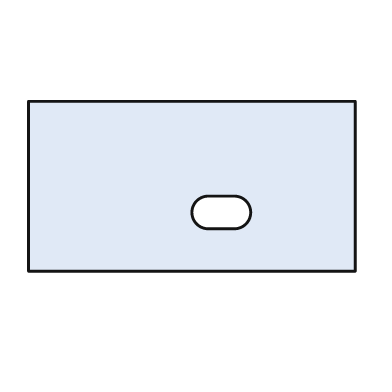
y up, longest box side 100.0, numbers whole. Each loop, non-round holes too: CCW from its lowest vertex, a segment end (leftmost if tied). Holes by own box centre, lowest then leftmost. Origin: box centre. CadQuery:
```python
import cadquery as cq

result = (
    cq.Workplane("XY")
    .moveTo(-50.0, -26.0)
    .lineTo(50.0, -26.0)
    .lineTo(50.0, 26.0)
    .lineTo(-50.0, 26.0)
    .close()
    .moveTo(5.0, -13.0)
    .lineTo(13.0, -13.0)
    .threePointArc((18.0, -8.0), (13.0, -3.0))
    .lineTo(5.0, -3.0)
    .threePointArc((0.0, -8.0), (5.0, -13.0))
    .close()
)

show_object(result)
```